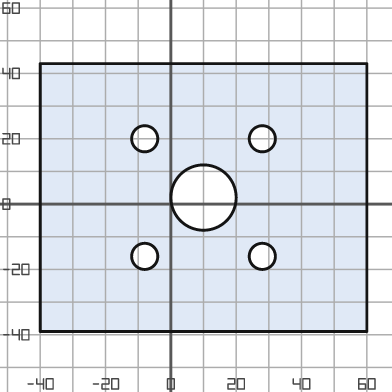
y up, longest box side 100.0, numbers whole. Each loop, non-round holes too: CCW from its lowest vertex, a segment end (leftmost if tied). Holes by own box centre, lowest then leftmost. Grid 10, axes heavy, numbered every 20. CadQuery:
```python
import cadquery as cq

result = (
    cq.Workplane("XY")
    .moveTo(-40.0, -39.0)
    .lineTo(60.0, -39.0)
    .lineTo(60.0, 43.0)
    .lineTo(-40.0, 43.0)
    .close()
    .moveTo(-8.0, -16.0)
    .circle(4.0)
    .moveTo(28.0, -16.0)
    .circle(4.0)
    .moveTo(10.0, 2.0)
    .circle(10.0)
    .moveTo(-8.0, 20.0)
    .circle(4.0)
    .moveTo(28.0, 20.0)
    .circle(4.0)
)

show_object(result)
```